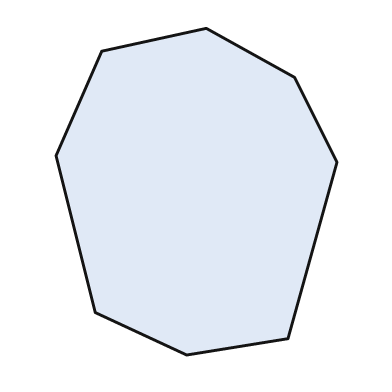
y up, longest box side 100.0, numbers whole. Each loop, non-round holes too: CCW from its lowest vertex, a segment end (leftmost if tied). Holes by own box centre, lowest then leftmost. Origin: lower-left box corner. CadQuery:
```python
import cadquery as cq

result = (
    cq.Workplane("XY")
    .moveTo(40.0, 0.0)
    .lineTo(71.0, 5.0)
    .lineTo(86.0, 59.0)
    .lineTo(73.0, 85.0)
    .lineTo(46.0, 100.0)
    .lineTo(14.0, 93.0)
    .lineTo(0.0, 61.0)
    .lineTo(12.0, 13.0)
    .close()
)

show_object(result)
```